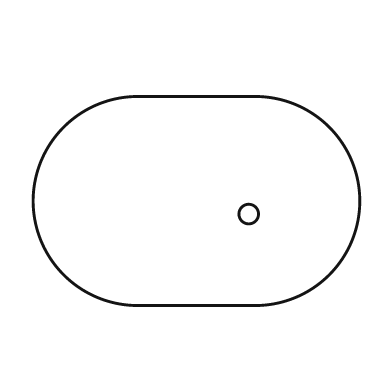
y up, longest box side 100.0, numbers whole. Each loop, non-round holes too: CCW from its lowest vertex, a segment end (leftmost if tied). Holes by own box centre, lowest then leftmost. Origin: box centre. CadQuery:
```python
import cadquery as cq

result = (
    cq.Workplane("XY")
    .moveTo(-18.0, -32.0)
    .lineTo(18.0, -32.0)
    .threePointArc((50.0, 0.0), (18.0, 32.0))
    .lineTo(-18.0, 32.0)
    .threePointArc((-50.0, 0.0), (-18.0, -32.0))
    .close()
    .moveTo(16.0, -4.0)
    .circle(3.0)
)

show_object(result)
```